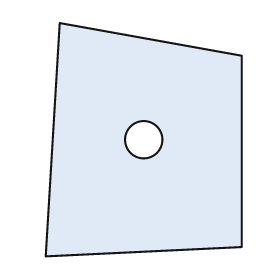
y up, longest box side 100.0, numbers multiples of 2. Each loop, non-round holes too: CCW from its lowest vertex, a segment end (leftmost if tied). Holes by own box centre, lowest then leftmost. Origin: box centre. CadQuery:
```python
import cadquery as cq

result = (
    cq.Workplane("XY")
    .moveTo(-42.0, -50.0)
    .lineTo(42.0, -46.0)
    .lineTo(42.0, 36.0)
    .lineTo(-36.0, 50.0)
    .close()
    .moveTo(0.0, 0.0)
    .circle(8.0)
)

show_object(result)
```